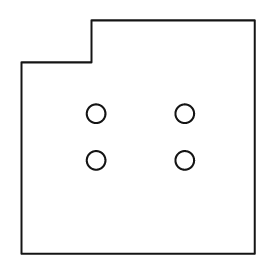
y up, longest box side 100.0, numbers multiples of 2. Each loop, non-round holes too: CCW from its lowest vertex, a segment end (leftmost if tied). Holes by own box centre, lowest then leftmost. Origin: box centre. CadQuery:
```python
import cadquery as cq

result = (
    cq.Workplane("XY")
    .moveTo(-50.0, -50.0)
    .lineTo(50.0, -50.0)
    .lineTo(50.0, 50.0)
    .lineTo(-20.0, 50.0)
    .lineTo(-20.0, 32.0)
    .lineTo(-50.0, 32.0)
    .close()
    .moveTo(-18.0, -10.0)
    .circle(4.0)
    .moveTo(20.0, -10.0)
    .circle(4.0)
    .moveTo(-18.0, 10.0)
    .circle(4.0)
    .moveTo(20.0, 10.0)
    .circle(4.0)
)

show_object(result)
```